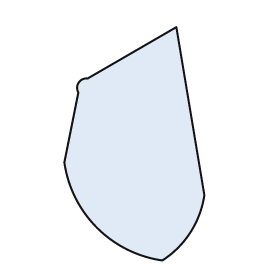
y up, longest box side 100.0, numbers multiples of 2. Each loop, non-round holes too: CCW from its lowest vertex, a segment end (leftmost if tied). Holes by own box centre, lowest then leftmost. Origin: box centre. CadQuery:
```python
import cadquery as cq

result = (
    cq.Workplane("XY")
    .moveTo(12.0, -50.0)
    .threePointArc((24.0, -38.0), (30.0, -22.0))
    .lineTo(18.0, 50.0)
    .lineTo(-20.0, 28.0)
    .threePointArc((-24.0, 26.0), (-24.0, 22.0))
    .lineTo(-30.0, -8.0)
    .threePointArc((-16.0, -36.0), (12.0, -50.0))
    .close()
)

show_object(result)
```